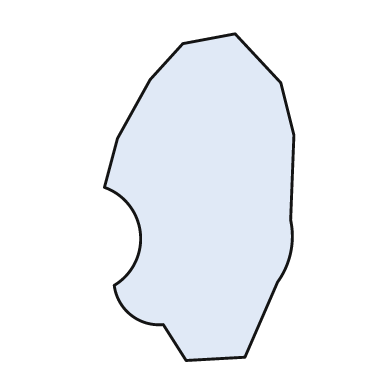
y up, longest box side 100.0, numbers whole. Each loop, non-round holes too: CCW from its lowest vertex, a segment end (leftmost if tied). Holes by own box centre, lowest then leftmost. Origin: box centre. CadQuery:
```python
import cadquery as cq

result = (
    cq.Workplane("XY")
    .moveTo(-4.0, -50.0)
    .lineTo(14.0, -49.0)
    .lineTo(24.0, -26.0)
    .threePointArc((28.0, -17.0), (28.0, -7.0))
    .lineTo(29.0, 19.0)
    .lineTo(25.0, 35.0)
    .lineTo(11.0, 50.0)
    .lineTo(-5.0, 47.0)
    .lineTo(-15.0, 36.0)
    .lineTo(-25.0, 18.0)
    .lineTo(-29.0, 3.0)
    .threePointArc((-18.0, -11.0), (-26.0, -27.0))
    .threePointArc((-21.0, -36.0), (-11.0, -39.0))
    .close()
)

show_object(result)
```